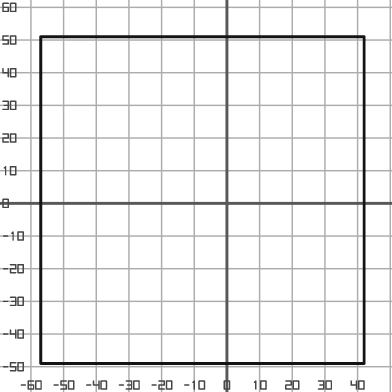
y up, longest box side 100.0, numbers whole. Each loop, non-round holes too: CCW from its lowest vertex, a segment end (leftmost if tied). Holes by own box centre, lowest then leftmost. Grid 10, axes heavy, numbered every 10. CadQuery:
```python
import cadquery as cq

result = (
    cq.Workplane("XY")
    .moveTo(-57.0, -49.0)
    .lineTo(42.0, -49.0)
    .lineTo(42.0, 51.0)
    .lineTo(-57.0, 51.0)
    .close()
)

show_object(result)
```